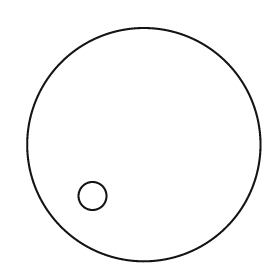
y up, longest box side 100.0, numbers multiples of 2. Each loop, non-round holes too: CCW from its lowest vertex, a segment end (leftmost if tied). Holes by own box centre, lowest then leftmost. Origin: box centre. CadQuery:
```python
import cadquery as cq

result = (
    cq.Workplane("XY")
    .moveTo(0.0, 0.0)
    .circle(50.0)
    .moveTo(-22.0, -22.0)
    .circle(6.0)
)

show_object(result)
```